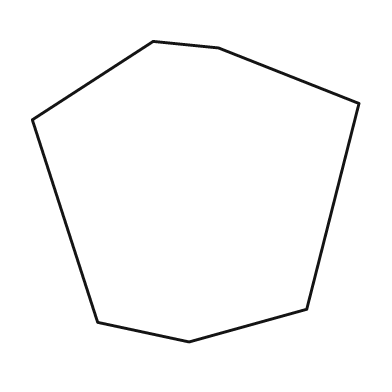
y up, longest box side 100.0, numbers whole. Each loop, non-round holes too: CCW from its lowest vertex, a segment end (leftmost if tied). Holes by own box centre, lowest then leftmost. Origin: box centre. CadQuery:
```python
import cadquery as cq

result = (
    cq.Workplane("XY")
    .moveTo(-2.0, -46.0)
    .lineTo(34.0, -36.0)
    .lineTo(50.0, 27.0)
    .lineTo(7.0, 44.0)
    .lineTo(-13.0, 46.0)
    .lineTo(-50.0, 22.0)
    .lineTo(-30.0, -40.0)
    .close()
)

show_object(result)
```